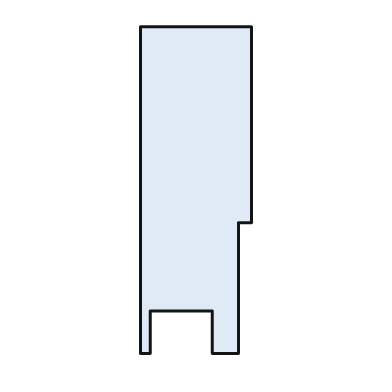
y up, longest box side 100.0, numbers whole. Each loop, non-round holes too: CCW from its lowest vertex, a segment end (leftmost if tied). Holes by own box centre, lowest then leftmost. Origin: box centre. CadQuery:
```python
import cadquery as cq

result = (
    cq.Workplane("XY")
    .moveTo(-17.0, -50.0)
    .lineTo(-14.0, -50.0)
    .lineTo(-14.0, -37.0)
    .lineTo(5.0, -37.0)
    .lineTo(5.0, -50.0)
    .lineTo(13.0, -50.0)
    .lineTo(13.0, -10.0)
    .lineTo(17.0, -10.0)
    .lineTo(17.0, 50.0)
    .lineTo(-17.0, 50.0)
    .close()
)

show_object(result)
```